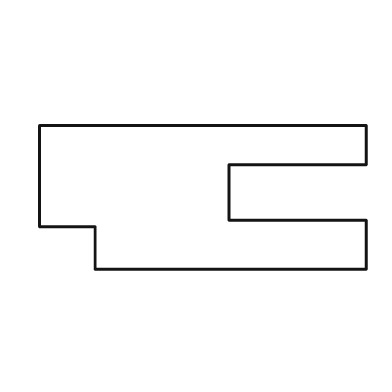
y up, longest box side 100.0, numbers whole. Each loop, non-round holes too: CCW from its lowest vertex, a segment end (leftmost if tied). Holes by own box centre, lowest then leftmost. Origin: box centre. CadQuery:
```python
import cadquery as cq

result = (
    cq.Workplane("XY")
    .moveTo(-33.0, -22.0)
    .lineTo(50.0, -22.0)
    .lineTo(50.0, -7.0)
    .lineTo(8.0, -7.0)
    .lineTo(8.0, 10.0)
    .lineTo(50.0, 10.0)
    .lineTo(50.0, 22.0)
    .lineTo(-50.0, 22.0)
    .lineTo(-50.0, -9.0)
    .lineTo(-33.0, -9.0)
    .close()
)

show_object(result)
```